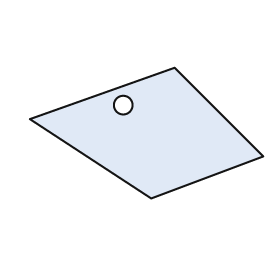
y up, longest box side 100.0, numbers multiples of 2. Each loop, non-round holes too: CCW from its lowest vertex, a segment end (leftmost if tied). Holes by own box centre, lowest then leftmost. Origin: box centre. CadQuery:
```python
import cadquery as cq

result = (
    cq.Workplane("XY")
    .moveTo(2.0, -28.0)
    .lineTo(50.0, -10.0)
    .lineTo(12.0, 28.0)
    .lineTo(-50.0, 6.0)
    .close()
    .moveTo(-10.0, 12.0)
    .circle(4.0)
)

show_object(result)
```